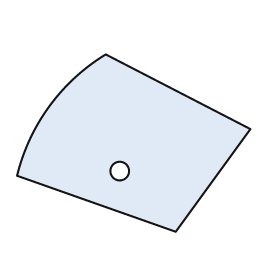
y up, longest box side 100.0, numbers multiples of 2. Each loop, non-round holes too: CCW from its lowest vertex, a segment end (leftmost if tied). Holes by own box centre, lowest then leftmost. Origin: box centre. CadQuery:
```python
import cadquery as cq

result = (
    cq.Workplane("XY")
    .moveTo(18.0, -38.0)
    .lineTo(50.0, 6.0)
    .lineTo(-12.0, 38.0)
    .threePointArc((-36.0, 16.0), (-50.0, -14.0))
    .close()
    .moveTo(-6.0, -12.0)
    .circle(4.0)
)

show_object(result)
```